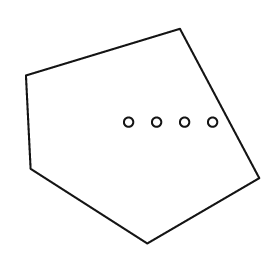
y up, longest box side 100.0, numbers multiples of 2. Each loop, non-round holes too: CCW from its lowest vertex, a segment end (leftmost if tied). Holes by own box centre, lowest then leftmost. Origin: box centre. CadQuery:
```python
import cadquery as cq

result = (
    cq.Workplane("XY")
    .moveTo(2.0, -46.0)
    .lineTo(50.0, -18.0)
    .lineTo(16.0, 46.0)
    .lineTo(-50.0, 26.0)
    .lineTo(-48.0, -14.0)
    .close()
    .moveTo(-6.0, 6.0)
    .circle(2.0)
    .moveTo(6.0, 6.0)
    .circle(2.0)
    .moveTo(18.0, 6.0)
    .circle(2.0)
    .moveTo(30.0, 6.0)
    .circle(2.0)
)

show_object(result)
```